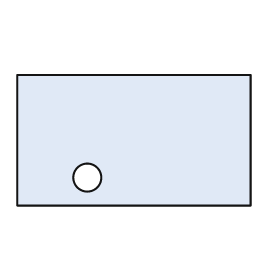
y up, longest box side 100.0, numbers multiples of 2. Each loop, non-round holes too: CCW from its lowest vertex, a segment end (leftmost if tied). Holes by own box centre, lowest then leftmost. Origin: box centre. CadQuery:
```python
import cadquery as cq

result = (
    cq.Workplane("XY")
    .moveTo(-50.0, -28.0)
    .lineTo(50.0, -28.0)
    .lineTo(50.0, 28.0)
    .lineTo(-50.0, 28.0)
    .close()
    .moveTo(-20.0, -16.0)
    .circle(6.0)
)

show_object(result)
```